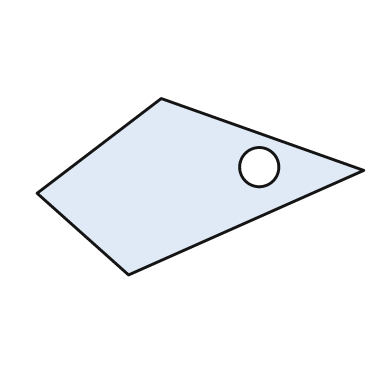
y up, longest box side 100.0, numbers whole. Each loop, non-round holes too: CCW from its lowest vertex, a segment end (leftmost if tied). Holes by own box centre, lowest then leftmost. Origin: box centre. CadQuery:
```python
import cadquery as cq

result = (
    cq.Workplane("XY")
    .moveTo(-22.0, -27.0)
    .lineTo(50.0, 5.0)
    .lineTo(-12.0, 27.0)
    .lineTo(-50.0, -2.0)
    .close()
    .moveTo(18.0, 6.0)
    .circle(6.0)
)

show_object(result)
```